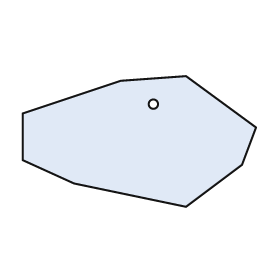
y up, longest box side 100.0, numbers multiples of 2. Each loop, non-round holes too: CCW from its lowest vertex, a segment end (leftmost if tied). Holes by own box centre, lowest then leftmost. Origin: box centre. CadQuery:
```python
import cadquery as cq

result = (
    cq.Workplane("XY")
    .moveTo(20.0, -28.0)
    .lineTo(44.0, -10.0)
    .lineTo(50.0, 6.0)
    .lineTo(20.0, 28.0)
    .lineTo(-8.0, 26.0)
    .lineTo(-50.0, 12.0)
    .lineTo(-50.0, -8.0)
    .lineTo(-28.0, -18.0)
    .close()
    .moveTo(6.0, 16.0)
    .circle(2.0)
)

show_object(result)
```